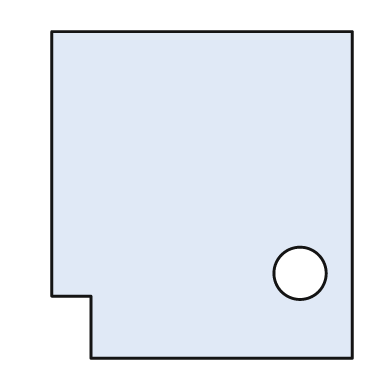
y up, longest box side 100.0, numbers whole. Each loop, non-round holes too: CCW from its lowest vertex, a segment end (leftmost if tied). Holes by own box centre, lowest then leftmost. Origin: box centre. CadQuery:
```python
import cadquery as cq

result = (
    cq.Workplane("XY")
    .moveTo(-34.0, -50.0)
    .lineTo(46.0, -50.0)
    .lineTo(46.0, 50.0)
    .lineTo(-46.0, 50.0)
    .lineTo(-46.0, -31.0)
    .lineTo(-34.0, -31.0)
    .close()
    .moveTo(30.0, -24.0)
    .circle(8.0)
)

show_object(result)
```